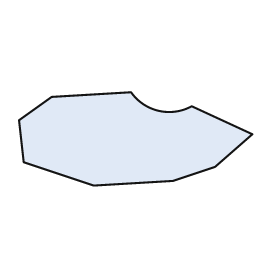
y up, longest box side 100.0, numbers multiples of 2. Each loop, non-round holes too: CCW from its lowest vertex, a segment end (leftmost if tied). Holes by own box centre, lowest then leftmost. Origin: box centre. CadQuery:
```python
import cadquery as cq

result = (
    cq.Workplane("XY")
    .moveTo(-18.0, -20.0)
    .lineTo(16.0, -18.0)
    .lineTo(34.0, -12.0)
    .lineTo(50.0, 2.0)
    .lineTo(24.0, 14.0)
    .threePointArc((10.0, 12.0), (-2.0, 20.0))
    .lineTo(-36.0, 18.0)
    .lineTo(-50.0, 8.0)
    .lineTo(-48.0, -10.0)
    .close()
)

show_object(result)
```